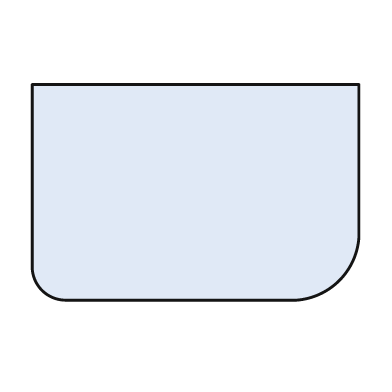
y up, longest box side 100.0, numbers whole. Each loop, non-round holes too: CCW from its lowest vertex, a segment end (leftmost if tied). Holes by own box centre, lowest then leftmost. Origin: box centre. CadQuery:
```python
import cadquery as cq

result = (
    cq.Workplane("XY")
    .moveTo(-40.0, -33.0)
    .lineTo(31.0, -33.0)
    .threePointArc((44.0, -27.0), (50.0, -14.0))
    .lineTo(50.0, 33.0)
    .lineTo(-50.0, 33.0)
    .lineTo(-50.0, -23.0)
    .threePointArc((-47.0, -30.0), (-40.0, -33.0))
    .close()
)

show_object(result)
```